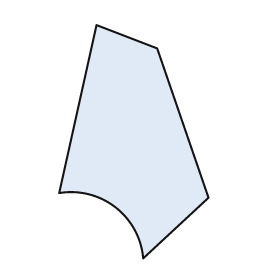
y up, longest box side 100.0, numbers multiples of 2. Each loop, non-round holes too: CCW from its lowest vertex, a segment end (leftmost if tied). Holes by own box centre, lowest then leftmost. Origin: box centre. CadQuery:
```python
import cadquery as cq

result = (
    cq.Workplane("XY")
    .moveTo(4.0, -50.0)
    .lineTo(32.0, -24.0)
    .lineTo(10.0, 40.0)
    .lineTo(-16.0, 50.0)
    .lineTo(-32.0, -22.0)
    .threePointArc((-8.0, -28.0), (4.0, -50.0))
    .close()
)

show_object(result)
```